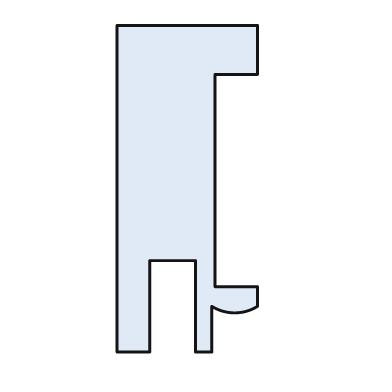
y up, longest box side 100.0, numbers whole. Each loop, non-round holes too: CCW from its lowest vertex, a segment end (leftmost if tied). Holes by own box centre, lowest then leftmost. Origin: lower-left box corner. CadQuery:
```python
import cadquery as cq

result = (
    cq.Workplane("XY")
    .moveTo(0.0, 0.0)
    .lineTo(10.0, 0.0)
    .lineTo(10.0, 28.0)
    .lineTo(24.0, 28.0)
    .lineTo(24.0, 0.0)
    .lineTo(29.0, 0.0)
    .lineTo(29.0, 14.0)
    .threePointArc((36.0, 12.0), (43.0, 14.0))
    .lineTo(43.0, 20.0)
    .lineTo(30.0, 20.0)
    .lineTo(30.0, 85.0)
    .lineTo(43.0, 85.0)
    .lineTo(43.0, 100.0)
    .lineTo(0.0, 100.0)
    .close()
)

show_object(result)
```